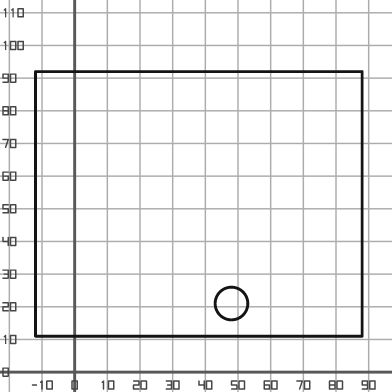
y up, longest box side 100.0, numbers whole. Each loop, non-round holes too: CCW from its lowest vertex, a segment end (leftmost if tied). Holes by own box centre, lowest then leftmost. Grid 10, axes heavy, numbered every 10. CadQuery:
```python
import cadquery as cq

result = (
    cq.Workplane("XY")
    .moveTo(-12.0, 11.0)
    .lineTo(88.0, 11.0)
    .lineTo(88.0, 92.0)
    .lineTo(-12.0, 92.0)
    .close()
    .moveTo(48.0, 21.0)
    .circle(5.0)
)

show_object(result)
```